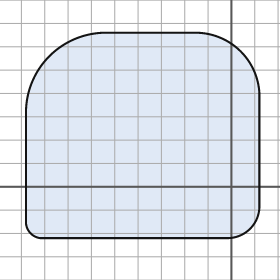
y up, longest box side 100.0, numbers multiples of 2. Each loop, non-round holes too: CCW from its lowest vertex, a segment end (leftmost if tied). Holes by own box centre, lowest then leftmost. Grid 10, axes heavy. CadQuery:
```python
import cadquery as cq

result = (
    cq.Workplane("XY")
    .moveTo(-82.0, -22.0)
    .lineTo(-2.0, -22.0)
    .threePointArc((8.0, -18.0), (12.0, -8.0))
    .lineTo(12.0, 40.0)
    .threePointArc((4.0, 58.0), (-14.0, 66.0))
    .lineTo(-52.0, 66.0)
    .threePointArc((-78.0, 56.0), (-88.0, 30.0))
    .lineTo(-88.0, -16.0)
    .threePointArc((-86.0, -20.0), (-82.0, -22.0))
    .close()
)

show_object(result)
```